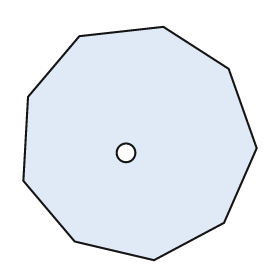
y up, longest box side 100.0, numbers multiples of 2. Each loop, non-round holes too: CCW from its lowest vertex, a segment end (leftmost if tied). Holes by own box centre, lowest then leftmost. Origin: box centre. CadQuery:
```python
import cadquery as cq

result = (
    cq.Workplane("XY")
    .moveTo(6.0, -50.0)
    .lineTo(36.0, -34.0)
    .lineTo(50.0, -2.0)
    .lineTo(38.0, 32.0)
    .lineTo(10.0, 50.0)
    .lineTo(-26.0, 46.0)
    .lineTo(-48.0, 20.0)
    .lineTo(-50.0, -16.0)
    .lineTo(-28.0, -42.0)
    .close()
    .moveTo(-6.0, -4.0)
    .circle(4.0)
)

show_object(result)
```